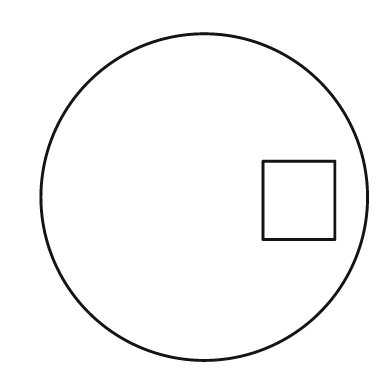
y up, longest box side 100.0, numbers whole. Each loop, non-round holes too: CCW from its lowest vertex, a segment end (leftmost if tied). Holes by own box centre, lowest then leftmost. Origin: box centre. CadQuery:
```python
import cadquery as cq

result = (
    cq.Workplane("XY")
    .moveTo(0.0, 0.0)
    .circle(50.0)
    .moveTo(18.0, -13.0)
    .lineTo(40.0, -13.0)
    .lineTo(40.0, 11.0)
    .lineTo(18.0, 11.0)
    .close()
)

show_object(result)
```